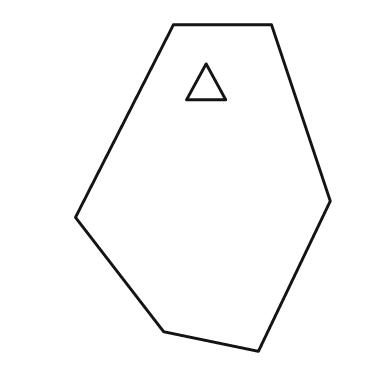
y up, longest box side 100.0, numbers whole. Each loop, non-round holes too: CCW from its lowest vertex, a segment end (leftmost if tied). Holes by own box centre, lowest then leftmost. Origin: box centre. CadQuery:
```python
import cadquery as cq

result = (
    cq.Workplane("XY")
    .moveTo(17.0, -50.0)
    .lineTo(39.0, -4.0)
    .lineTo(21.0, 50.0)
    .lineTo(-9.0, 50.0)
    .lineTo(-39.0, -9.0)
    .lineTo(-12.0, -44.0)
    .close()
    .moveTo(-5.0, 27.0)
    .lineTo(7.0, 27.0)
    .lineTo(1.0, 38.0)
    .close()
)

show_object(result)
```